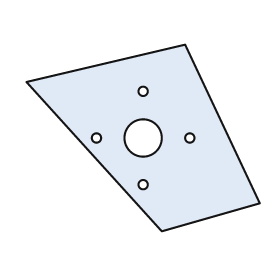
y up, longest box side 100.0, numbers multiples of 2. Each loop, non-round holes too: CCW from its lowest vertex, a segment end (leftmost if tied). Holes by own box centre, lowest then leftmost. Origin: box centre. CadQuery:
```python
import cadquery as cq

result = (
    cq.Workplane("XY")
    .moveTo(8.0, -40.0)
    .lineTo(50.0, -28.0)
    .lineTo(18.0, 40.0)
    .lineTo(-50.0, 24.0)
    .close()
    .moveTo(0.0, -20.0)
    .circle(2.0)
    .moveTo(-20.0, 0.0)
    .circle(2.0)
    .moveTo(0.0, 0.0)
    .circle(8.0)
    .moveTo(20.0, 0.0)
    .circle(2.0)
    .moveTo(0.0, 20.0)
    .circle(2.0)
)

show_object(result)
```